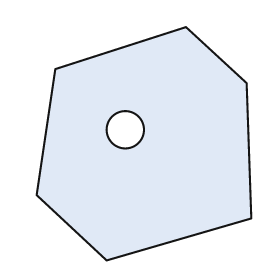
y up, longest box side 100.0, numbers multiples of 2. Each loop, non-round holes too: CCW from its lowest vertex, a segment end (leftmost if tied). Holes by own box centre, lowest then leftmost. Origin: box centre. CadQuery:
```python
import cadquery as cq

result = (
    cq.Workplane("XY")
    .moveTo(-16.0, -50.0)
    .lineTo(46.0, -32.0)
    .lineTo(44.0, 26.0)
    .lineTo(18.0, 50.0)
    .lineTo(-38.0, 32.0)
    .lineTo(-46.0, -22.0)
    .close()
    .moveTo(-8.0, 6.0)
    .circle(8.0)
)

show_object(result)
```